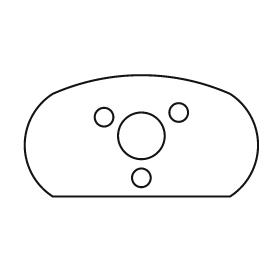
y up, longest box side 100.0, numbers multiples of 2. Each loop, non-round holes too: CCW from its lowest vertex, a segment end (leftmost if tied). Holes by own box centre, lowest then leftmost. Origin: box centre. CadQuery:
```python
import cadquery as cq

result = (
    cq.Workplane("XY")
    .moveTo(-38.0, -26.0)
    .lineTo(38.0, -26.0)
    .threePointArc((50.0, -4.0), (38.0, 18.0))
    .threePointArc((0.0, 26.0), (-38.0, 18.0))
    .threePointArc((-50.0, -4.0), (-38.0, -26.0))
    .close()
    .moveTo(0.0, -18.0)
    .circle(4.0)
    .moveTo(0.0, 0.0)
    .circle(10.0)
    .moveTo(-16.0, 8.0)
    .circle(4.0)
    .moveTo(16.0, 10.0)
    .circle(4.0)
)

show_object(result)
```